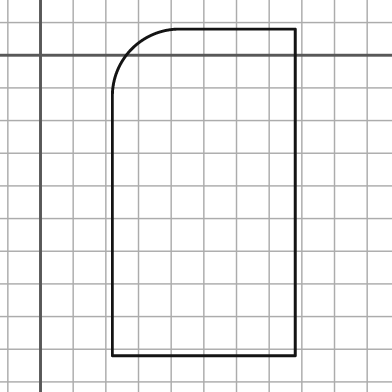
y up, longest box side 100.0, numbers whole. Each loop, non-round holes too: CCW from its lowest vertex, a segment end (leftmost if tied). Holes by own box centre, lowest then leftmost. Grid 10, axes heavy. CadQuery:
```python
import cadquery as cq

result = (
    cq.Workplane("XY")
    .moveTo(22.0, -92.0)
    .lineTo(78.0, -92.0)
    .lineTo(78.0, 8.0)
    .lineTo(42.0, 8.0)
    .threePointArc((28.0, 2.0), (22.0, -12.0))
    .close()
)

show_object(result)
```